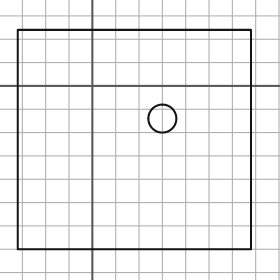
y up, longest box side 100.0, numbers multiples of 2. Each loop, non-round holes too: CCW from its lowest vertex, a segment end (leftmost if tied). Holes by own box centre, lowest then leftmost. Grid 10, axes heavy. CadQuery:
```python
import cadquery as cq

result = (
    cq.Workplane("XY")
    .moveTo(-32.0, -70.0)
    .lineTo(68.0, -70.0)
    .lineTo(68.0, 24.0)
    .lineTo(-32.0, 24.0)
    .close()
    .moveTo(30.0, -14.0)
    .circle(6.0)
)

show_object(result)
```